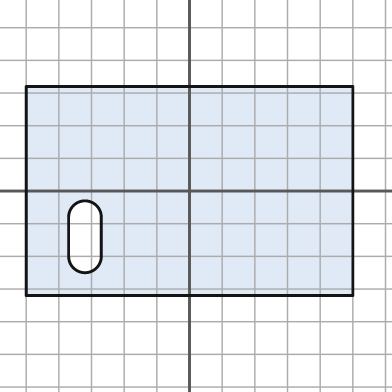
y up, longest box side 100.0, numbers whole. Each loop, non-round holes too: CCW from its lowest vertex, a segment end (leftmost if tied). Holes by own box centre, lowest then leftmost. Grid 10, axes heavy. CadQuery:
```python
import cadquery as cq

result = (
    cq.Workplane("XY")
    .moveTo(-50.0, -32.0)
    .lineTo(50.0, -32.0)
    .lineTo(50.0, 32.0)
    .lineTo(-50.0, 32.0)
    .close()
    .moveTo(-37.0, -20.0)
    .threePointArc((-32.0, -25.0), (-27.0, -20.0))
    .lineTo(-27.0, -8.0)
    .threePointArc((-32.0, -3.0), (-37.0, -8.0))
    .close()
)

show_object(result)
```